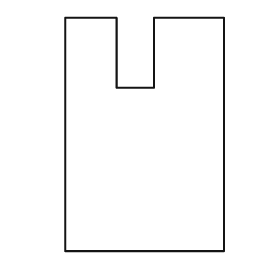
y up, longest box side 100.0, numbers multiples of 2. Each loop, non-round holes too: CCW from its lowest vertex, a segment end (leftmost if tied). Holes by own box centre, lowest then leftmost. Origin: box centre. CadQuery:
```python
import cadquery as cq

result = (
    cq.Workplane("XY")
    .moveTo(-34.0, -50.0)
    .lineTo(34.0, -50.0)
    .lineTo(34.0, 50.0)
    .lineTo(4.0, 50.0)
    .lineTo(4.0, 20.0)
    .lineTo(-12.0, 20.0)
    .lineTo(-12.0, 50.0)
    .lineTo(-34.0, 50.0)
    .close()
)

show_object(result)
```